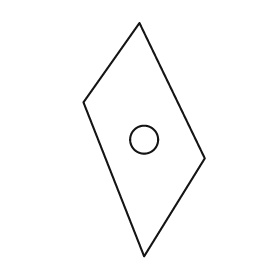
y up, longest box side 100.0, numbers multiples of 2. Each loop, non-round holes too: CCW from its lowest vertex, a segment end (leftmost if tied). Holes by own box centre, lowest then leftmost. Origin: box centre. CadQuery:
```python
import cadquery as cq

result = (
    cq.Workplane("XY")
    .moveTo(0.0, -50.0)
    .lineTo(26.0, -8.0)
    .lineTo(-2.0, 50.0)
    .lineTo(-26.0, 16.0)
    .close()
    .moveTo(0.0, 0.0)
    .circle(6.0)
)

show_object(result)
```